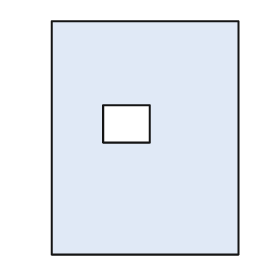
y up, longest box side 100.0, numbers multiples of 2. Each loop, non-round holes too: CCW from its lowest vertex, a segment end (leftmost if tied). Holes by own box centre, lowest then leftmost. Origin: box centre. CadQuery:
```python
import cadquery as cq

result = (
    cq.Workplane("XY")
    .moveTo(-40.0, -50.0)
    .lineTo(40.0, -50.0)
    .lineTo(40.0, 50.0)
    .lineTo(-40.0, 50.0)
    .close()
    .moveTo(-18.0, -2.0)
    .lineTo(2.0, -2.0)
    .lineTo(2.0, 14.0)
    .lineTo(-18.0, 14.0)
    .close()
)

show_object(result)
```